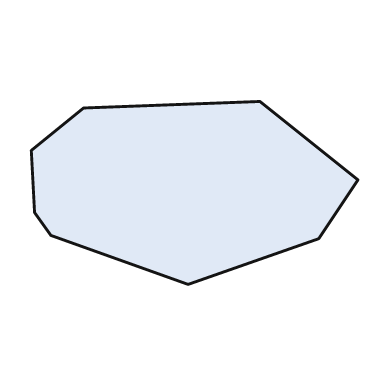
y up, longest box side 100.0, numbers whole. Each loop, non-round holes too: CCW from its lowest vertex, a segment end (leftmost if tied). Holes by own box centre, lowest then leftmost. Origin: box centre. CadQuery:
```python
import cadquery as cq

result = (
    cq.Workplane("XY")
    .moveTo(-2.0, -28.0)
    .lineTo(38.0, -14.0)
    .lineTo(50.0, 4.0)
    .lineTo(20.0, 28.0)
    .lineTo(-34.0, 26.0)
    .lineTo(-50.0, 13.0)
    .lineTo(-49.0, -6.0)
    .lineTo(-44.0, -13.0)
    .close()
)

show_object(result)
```